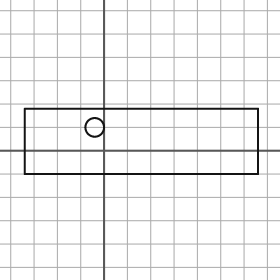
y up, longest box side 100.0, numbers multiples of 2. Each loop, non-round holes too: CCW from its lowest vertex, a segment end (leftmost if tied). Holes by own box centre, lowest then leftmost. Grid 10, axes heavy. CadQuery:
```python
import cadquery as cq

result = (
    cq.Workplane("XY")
    .moveTo(-34.0, -10.0)
    .lineTo(66.0, -10.0)
    .lineTo(66.0, 18.0)
    .lineTo(-34.0, 18.0)
    .close()
    .moveTo(-4.0, 10.0)
    .circle(4.0)
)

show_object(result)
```